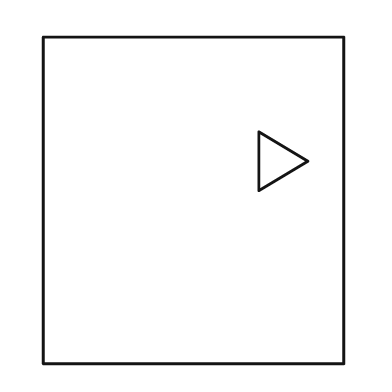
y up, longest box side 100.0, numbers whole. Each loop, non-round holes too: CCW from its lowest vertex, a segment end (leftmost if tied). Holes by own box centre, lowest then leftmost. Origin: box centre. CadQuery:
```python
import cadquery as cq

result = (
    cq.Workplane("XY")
    .moveTo(-46.0, -50.0)
    .lineTo(46.0, -50.0)
    .lineTo(46.0, 50.0)
    .lineTo(-46.0, 50.0)
    .close()
    .moveTo(20.0, 3.0)
    .lineTo(35.0, 12.0)
    .lineTo(20.0, 21.0)
    .close()
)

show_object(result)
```